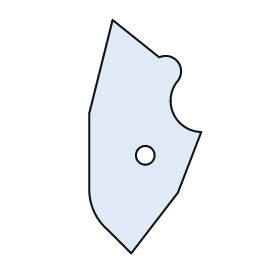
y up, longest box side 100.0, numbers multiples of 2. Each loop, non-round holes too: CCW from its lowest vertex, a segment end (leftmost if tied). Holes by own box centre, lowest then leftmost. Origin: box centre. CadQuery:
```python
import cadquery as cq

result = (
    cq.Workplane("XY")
    .moveTo(-6.0, -50.0)
    .lineTo(14.0, -24.0)
    .lineTo(24.0, 2.0)
    .threePointArc((12.0, 10.0), (14.0, 24.0))
    .threePointArc((14.0, 32.0), (6.0, 34.0))
    .lineTo(-14.0, 50.0)
    .lineTo(-24.0, 10.0)
    .lineTo(-24.0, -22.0)
    .threePointArc((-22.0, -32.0), (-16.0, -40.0))
    .close()
    .moveTo(0.0, -8.0)
    .circle(4.0)
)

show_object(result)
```